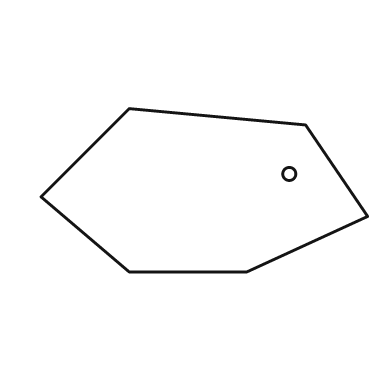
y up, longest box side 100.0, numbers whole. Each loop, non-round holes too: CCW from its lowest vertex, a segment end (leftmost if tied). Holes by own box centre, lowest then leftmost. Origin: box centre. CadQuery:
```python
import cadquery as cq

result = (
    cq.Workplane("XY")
    .moveTo(-23.0, -25.0)
    .lineTo(13.0, -25.0)
    .lineTo(50.0, -8.0)
    .lineTo(31.0, 20.0)
    .lineTo(-23.0, 25.0)
    .lineTo(-50.0, -2.0)
    .close()
    .moveTo(26.0, 5.0)
    .circle(2.0)
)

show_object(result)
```